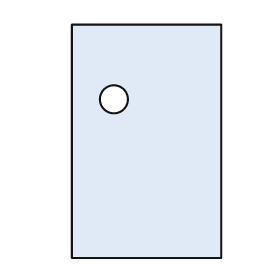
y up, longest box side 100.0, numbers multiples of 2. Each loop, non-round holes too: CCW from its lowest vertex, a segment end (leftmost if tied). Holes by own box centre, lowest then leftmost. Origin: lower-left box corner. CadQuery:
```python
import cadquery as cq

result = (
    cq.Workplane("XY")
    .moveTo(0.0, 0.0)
    .lineTo(64.0, 0.0)
    .lineTo(64.0, 100.0)
    .lineTo(0.0, 100.0)
    .close()
    .moveTo(18.0, 68.0)
    .circle(6.0)
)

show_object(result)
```